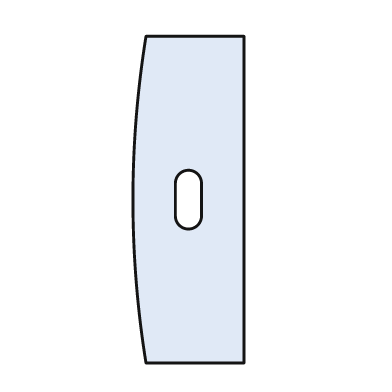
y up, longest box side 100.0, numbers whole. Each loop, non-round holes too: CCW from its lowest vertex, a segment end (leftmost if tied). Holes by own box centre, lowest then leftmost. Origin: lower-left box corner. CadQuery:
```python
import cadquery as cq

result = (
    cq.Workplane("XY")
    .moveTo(4.0, 0.0)
    .lineTo(34.0, 0.0)
    .lineTo(34.0, 100.0)
    .lineTo(4.0, 100.0)
    .threePointArc((0.0, 50.0), (4.0, 0.0))
    .close()
    .moveTo(13.0, 45.0)
    .threePointArc((17.0, 41.0), (21.0, 45.0))
    .lineTo(21.0, 55.0)
    .threePointArc((17.0, 59.0), (13.0, 55.0))
    .close()
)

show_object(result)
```